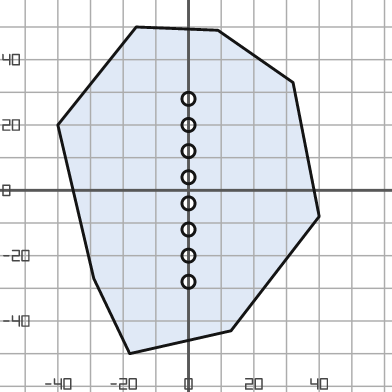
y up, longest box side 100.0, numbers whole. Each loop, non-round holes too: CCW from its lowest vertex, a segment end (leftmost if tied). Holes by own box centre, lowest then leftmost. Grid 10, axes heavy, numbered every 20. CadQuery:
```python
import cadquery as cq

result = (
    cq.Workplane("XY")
    .moveTo(-18.0, -50.0)
    .lineTo(13.0, -43.0)
    .lineTo(40.0, -8.0)
    .lineTo(32.0, 33.0)
    .lineTo(9.0, 49.0)
    .lineTo(-16.0, 50.0)
    .lineTo(-40.0, 20.0)
    .lineTo(-29.0, -27.0)
    .close()
    .moveTo(0.0, -28.0)
    .circle(2.0)
    .moveTo(0.0, -20.0)
    .circle(2.0)
    .moveTo(0.0, -12.0)
    .circle(2.0)
    .moveTo(0.0, -4.0)
    .circle(2.0)
    .moveTo(0.0, 4.0)
    .circle(2.0)
    .moveTo(0.0, 12.0)
    .circle(2.0)
    .moveTo(0.0, 20.0)
    .circle(2.0)
    .moveTo(0.0, 28.0)
    .circle(2.0)
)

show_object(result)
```